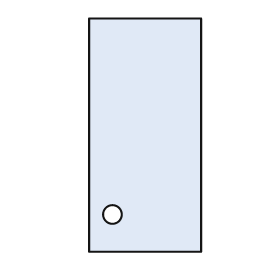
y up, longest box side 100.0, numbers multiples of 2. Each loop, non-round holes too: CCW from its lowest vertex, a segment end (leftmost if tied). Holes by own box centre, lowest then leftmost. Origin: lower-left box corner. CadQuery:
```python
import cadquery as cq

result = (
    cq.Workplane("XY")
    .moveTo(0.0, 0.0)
    .lineTo(48.0, 0.0)
    .lineTo(48.0, 100.0)
    .lineTo(0.0, 100.0)
    .close()
    .moveTo(10.0, 16.0)
    .circle(4.0)
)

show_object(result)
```